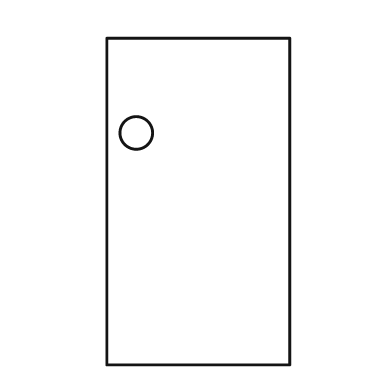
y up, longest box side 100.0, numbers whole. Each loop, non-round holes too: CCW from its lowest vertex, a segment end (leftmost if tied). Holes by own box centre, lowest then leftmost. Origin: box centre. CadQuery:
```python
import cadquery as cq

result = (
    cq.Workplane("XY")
    .moveTo(-28.0, -50.0)
    .lineTo(28.0, -50.0)
    .lineTo(28.0, 50.0)
    .lineTo(-28.0, 50.0)
    .close()
    .moveTo(-19.0, 21.0)
    .circle(5.0)
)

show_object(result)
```